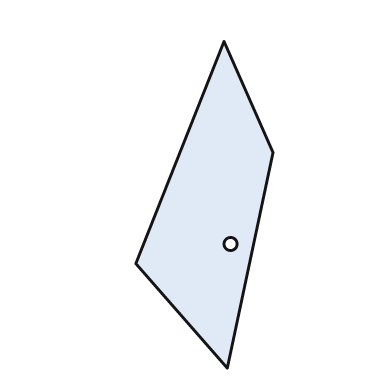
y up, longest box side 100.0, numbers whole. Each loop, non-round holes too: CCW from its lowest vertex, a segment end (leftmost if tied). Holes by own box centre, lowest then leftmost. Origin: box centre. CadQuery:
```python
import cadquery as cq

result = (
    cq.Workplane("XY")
    .moveTo(7.0, -50.0)
    .lineTo(21.0, 16.0)
    .lineTo(6.0, 50.0)
    .lineTo(-21.0, -18.0)
    .close()
    .moveTo(8.0, -12.0)
    .circle(2.0)
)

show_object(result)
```